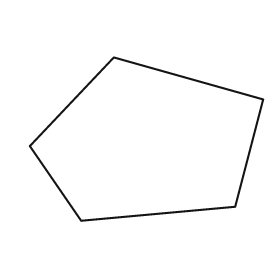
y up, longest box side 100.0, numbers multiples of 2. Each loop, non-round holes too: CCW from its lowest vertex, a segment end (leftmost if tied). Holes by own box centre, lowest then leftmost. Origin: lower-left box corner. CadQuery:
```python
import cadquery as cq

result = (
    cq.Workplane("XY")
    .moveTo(22.0, 0.0)
    .lineTo(88.0, 6.0)
    .lineTo(100.0, 52.0)
    .lineTo(36.0, 70.0)
    .lineTo(0.0, 32.0)
    .close()
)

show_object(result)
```